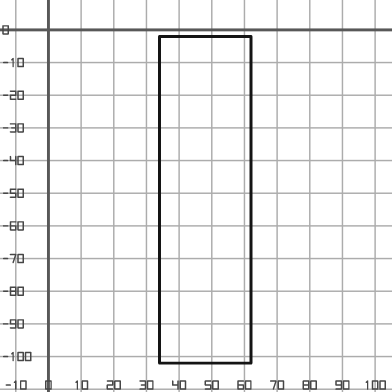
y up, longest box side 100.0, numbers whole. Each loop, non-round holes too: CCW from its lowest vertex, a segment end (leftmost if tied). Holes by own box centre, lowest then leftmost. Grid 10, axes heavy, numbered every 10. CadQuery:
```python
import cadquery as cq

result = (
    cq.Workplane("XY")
    .moveTo(34.0, -102.0)
    .lineTo(62.0, -102.0)
    .lineTo(62.0, -2.0)
    .lineTo(34.0, -2.0)
    .close()
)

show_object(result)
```